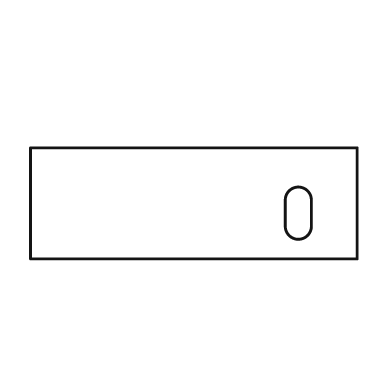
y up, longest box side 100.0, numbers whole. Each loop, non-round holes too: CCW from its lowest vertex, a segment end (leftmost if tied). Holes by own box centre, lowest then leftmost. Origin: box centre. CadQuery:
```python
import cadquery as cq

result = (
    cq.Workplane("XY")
    .moveTo(-50.0, -17.0)
    .lineTo(50.0, -17.0)
    .lineTo(50.0, 17.0)
    .lineTo(-50.0, 17.0)
    .close()
    .moveTo(28.0, -7.0)
    .threePointArc((32.0, -11.0), (36.0, -7.0))
    .lineTo(36.0, 1.0)
    .threePointArc((32.0, 5.0), (28.0, 1.0))
    .close()
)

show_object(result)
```